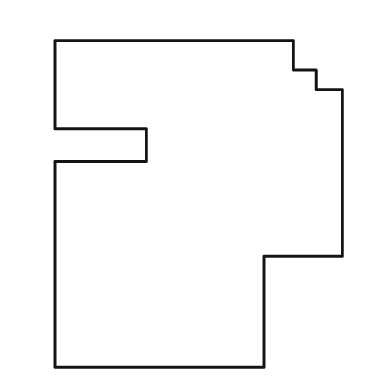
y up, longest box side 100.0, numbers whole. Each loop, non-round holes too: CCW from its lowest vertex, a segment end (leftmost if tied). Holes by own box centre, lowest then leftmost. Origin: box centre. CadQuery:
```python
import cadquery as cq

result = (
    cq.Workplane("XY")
    .moveTo(-44.0, -50.0)
    .lineTo(20.0, -50.0)
    .lineTo(20.0, -16.0)
    .lineTo(44.0, -16.0)
    .lineTo(44.0, 35.0)
    .lineTo(36.0, 35.0)
    .lineTo(36.0, 41.0)
    .lineTo(29.0, 41.0)
    .lineTo(29.0, 50.0)
    .lineTo(-44.0, 50.0)
    .lineTo(-44.0, 23.0)
    .lineTo(-16.0, 23.0)
    .lineTo(-16.0, 13.0)
    .lineTo(-44.0, 13.0)
    .close()
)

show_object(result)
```